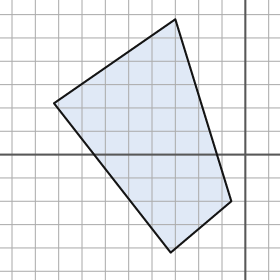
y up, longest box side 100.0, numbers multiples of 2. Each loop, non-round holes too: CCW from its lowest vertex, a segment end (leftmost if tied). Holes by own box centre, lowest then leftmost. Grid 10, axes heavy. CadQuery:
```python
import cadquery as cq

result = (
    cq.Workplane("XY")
    .moveTo(-32.0, -42.0)
    .lineTo(-6.0, -20.0)
    .lineTo(-30.0, 58.0)
    .lineTo(-82.0, 22.0)
    .close()
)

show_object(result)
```